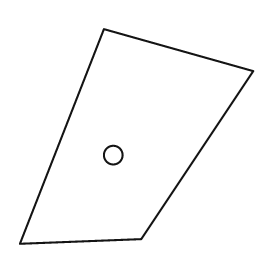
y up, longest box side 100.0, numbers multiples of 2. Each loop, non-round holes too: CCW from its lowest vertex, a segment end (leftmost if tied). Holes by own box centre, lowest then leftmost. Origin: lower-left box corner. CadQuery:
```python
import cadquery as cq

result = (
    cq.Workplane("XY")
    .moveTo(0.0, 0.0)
    .lineTo(52.0, 2.0)
    .lineTo(100.0, 74.0)
    .lineTo(36.0, 92.0)
    .close()
    .moveTo(40.0, 38.0)
    .circle(4.0)
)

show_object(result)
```